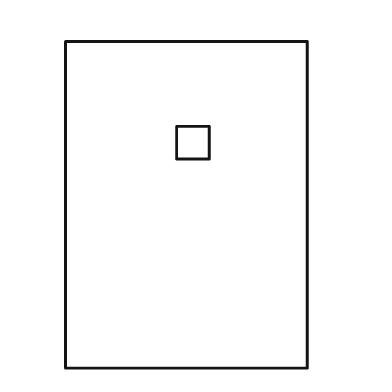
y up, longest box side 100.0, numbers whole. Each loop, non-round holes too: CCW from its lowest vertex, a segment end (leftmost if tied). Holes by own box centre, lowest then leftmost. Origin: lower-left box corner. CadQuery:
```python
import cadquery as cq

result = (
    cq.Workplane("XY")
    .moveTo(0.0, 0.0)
    .lineTo(74.0, 0.0)
    .lineTo(74.0, 100.0)
    .lineTo(0.0, 100.0)
    .close()
    .moveTo(34.0, 64.0)
    .lineTo(44.0, 64.0)
    .lineTo(44.0, 74.0)
    .lineTo(34.0, 74.0)
    .close()
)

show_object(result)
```